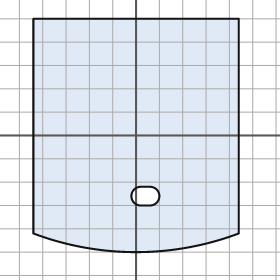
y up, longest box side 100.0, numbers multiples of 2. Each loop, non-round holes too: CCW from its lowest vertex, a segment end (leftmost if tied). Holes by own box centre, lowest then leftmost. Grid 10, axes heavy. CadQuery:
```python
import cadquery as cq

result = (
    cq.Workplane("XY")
    .moveTo(-44.0, -42.0)
    .threePointArc((0.0, -50.0), (44.0, -42.0))
    .lineTo(44.0, 50.0)
    .lineTo(-44.0, 50.0)
    .close()
    .moveTo(2.0, -30.0)
    .lineTo(6.0, -30.0)
    .threePointArc((10.0, -26.0), (6.0, -22.0))
    .lineTo(2.0, -22.0)
    .threePointArc((-2.0, -26.0), (2.0, -30.0))
    .close()
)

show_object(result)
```